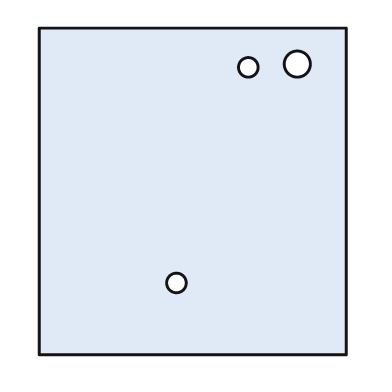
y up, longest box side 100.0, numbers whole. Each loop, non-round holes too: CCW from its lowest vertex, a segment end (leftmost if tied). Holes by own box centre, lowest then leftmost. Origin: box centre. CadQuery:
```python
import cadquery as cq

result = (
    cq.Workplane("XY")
    .moveTo(-47.0, -50.0)
    .lineTo(47.0, -50.0)
    .lineTo(47.0, 50.0)
    .lineTo(-47.0, 50.0)
    .close()
    .moveTo(-5.0, -28.0)
    .circle(3.0)
    .moveTo(17.0, 38.0)
    .circle(3.0)
    .moveTo(32.0, 39.0)
    .circle(4.0)
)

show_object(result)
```